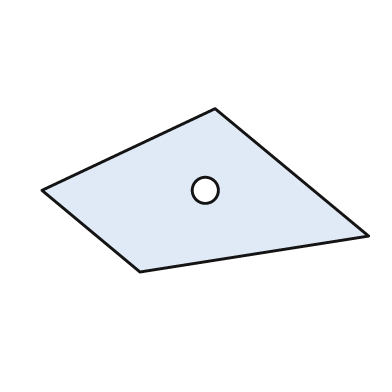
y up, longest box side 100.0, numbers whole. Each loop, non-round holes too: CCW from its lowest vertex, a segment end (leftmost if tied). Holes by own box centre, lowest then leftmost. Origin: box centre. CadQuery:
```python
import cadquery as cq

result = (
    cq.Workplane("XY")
    .moveTo(-20.0, -25.0)
    .lineTo(50.0, -14.0)
    .lineTo(3.0, 25.0)
    .lineTo(-50.0, 0.0)
    .close()
    .moveTo(0.0, 0.0)
    .circle(4.0)
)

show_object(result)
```